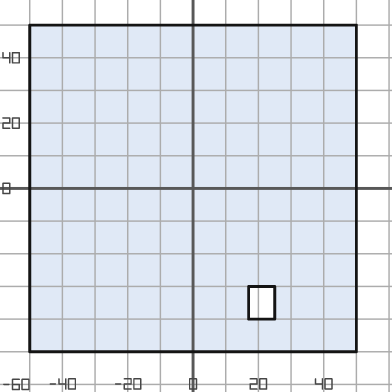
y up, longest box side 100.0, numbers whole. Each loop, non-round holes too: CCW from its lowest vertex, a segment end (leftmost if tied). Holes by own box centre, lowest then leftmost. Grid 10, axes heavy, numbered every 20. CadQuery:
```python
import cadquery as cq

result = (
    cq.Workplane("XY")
    .moveTo(-50.0, -50.0)
    .lineTo(50.0, -50.0)
    .lineTo(50.0, 50.0)
    .lineTo(-50.0, 50.0)
    .close()
    .moveTo(17.0, -40.0)
    .lineTo(25.0, -40.0)
    .lineTo(25.0, -30.0)
    .lineTo(17.0, -30.0)
    .close()
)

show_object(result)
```